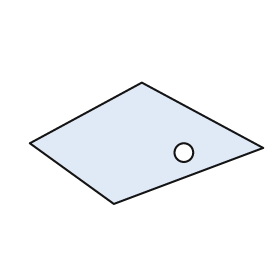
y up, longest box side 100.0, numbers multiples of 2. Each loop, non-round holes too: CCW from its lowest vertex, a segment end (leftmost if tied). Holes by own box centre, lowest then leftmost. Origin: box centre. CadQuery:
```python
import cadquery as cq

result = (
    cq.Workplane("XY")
    .moveTo(-14.0, -26.0)
    .lineTo(50.0, -2.0)
    .lineTo(-2.0, 26.0)
    .lineTo(-50.0, 0.0)
    .close()
    .moveTo(16.0, -4.0)
    .circle(4.0)
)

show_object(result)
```